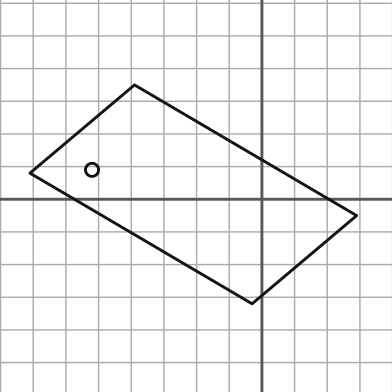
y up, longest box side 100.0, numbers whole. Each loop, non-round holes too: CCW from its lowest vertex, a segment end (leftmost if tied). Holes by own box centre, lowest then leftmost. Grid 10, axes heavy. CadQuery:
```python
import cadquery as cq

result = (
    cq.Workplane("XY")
    .moveTo(-3.0, -32.0)
    .lineTo(29.0, -5.0)
    .lineTo(-39.0, 35.0)
    .lineTo(-71.0, 8.0)
    .close()
    .moveTo(-52.0, 9.0)
    .circle(2.0)
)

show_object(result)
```